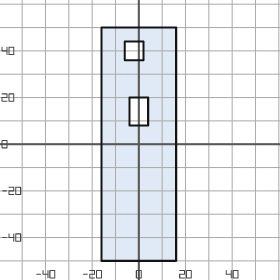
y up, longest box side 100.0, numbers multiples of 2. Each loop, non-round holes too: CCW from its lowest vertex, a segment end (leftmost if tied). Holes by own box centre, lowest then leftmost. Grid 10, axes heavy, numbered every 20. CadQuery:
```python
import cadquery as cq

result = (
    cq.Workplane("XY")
    .moveTo(-16.0, -50.0)
    .lineTo(16.0, -50.0)
    .lineTo(16.0, 50.0)
    .lineTo(-16.0, 50.0)
    .close()
    .moveTo(-4.0, 8.0)
    .lineTo(4.0, 8.0)
    .lineTo(4.0, 20.0)
    .lineTo(-4.0, 20.0)
    .close()
    .moveTo(-6.0, 36.0)
    .lineTo(2.0, 36.0)
    .lineTo(2.0, 44.0)
    .lineTo(-6.0, 44.0)
    .close()
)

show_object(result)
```